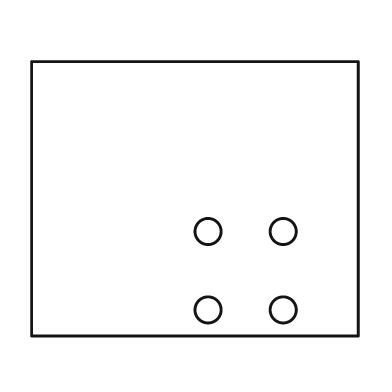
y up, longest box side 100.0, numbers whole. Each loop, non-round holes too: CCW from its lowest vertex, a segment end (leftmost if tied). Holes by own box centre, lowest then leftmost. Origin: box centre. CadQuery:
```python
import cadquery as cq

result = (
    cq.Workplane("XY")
    .moveTo(-50.0, -42.0)
    .lineTo(50.0, -42.0)
    .lineTo(50.0, 42.0)
    .lineTo(-50.0, 42.0)
    .close()
    .moveTo(4.0, -34.0)
    .circle(4.0)
    .moveTo(27.0, -34.0)
    .circle(4.0)
    .moveTo(4.0, -10.0)
    .circle(4.0)
    .moveTo(27.0, -10.0)
    .circle(4.0)
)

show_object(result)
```